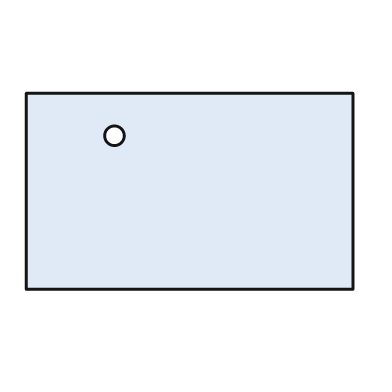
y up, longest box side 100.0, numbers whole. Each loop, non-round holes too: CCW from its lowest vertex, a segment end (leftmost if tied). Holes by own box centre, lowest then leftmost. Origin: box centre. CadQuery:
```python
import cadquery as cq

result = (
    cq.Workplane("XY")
    .moveTo(-50.0, -30.0)
    .lineTo(50.0, -30.0)
    .lineTo(50.0, 30.0)
    .lineTo(-50.0, 30.0)
    .close()
    .moveTo(-23.0, 17.0)
    .circle(3.0)
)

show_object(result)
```